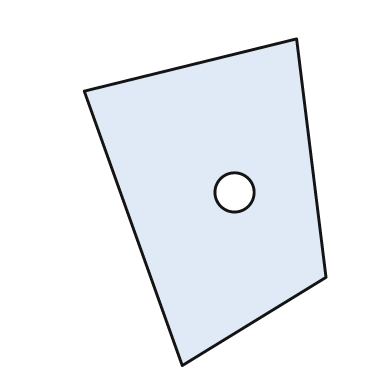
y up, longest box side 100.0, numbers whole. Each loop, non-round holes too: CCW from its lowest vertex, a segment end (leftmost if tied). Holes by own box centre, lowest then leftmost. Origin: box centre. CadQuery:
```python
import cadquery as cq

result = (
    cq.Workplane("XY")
    .moveTo(-7.0, -50.0)
    .lineTo(37.0, -23.0)
    .lineTo(28.0, 50.0)
    .lineTo(-37.0, 34.0)
    .close()
    .moveTo(9.0, 3.0)
    .circle(6.0)
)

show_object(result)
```